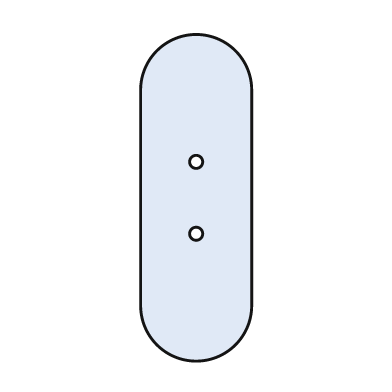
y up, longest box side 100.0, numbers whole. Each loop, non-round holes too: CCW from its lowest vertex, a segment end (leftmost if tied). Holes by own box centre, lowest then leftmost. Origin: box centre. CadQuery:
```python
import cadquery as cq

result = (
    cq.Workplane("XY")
    .moveTo(-17.0, -33.0)
    .threePointArc((0.0, -50.0), (17.0, -33.0))
    .lineTo(17.0, 33.0)
    .threePointArc((0.0, 50.0), (-17.0, 33.0))
    .close()
    .moveTo(0.0, -11.0)
    .circle(2.0)
    .moveTo(0.0, 11.0)
    .circle(2.0)
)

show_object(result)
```